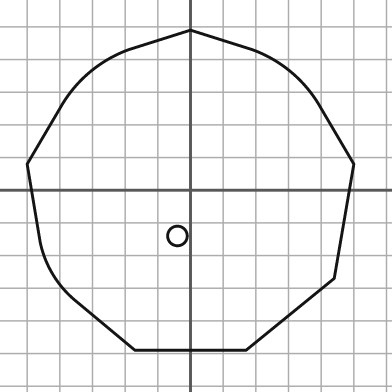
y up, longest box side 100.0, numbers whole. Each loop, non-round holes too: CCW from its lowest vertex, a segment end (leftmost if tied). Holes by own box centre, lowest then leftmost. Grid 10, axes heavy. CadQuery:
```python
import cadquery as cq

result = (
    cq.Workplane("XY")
    .moveTo(-17.0, -49.0)
    .lineTo(17.0, -49.0)
    .lineTo(44.0, -27.0)
    .lineTo(50.0, 8.0)
    .lineTo(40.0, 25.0)
    .threePointArc((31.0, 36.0), (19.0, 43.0))
    .lineTo(0.0, 49.0)
    .lineTo(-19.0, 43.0)
    .threePointArc((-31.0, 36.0), (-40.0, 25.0))
    .lineTo(-50.0, 8.0)
    .lineTo(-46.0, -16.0)
    .threePointArc((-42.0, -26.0), (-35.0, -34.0))
    .close()
    .moveTo(-4.0, -14.0)
    .circle(3.0)
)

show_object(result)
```